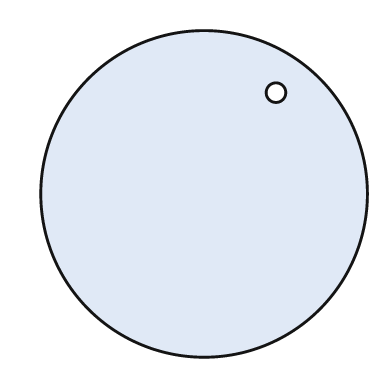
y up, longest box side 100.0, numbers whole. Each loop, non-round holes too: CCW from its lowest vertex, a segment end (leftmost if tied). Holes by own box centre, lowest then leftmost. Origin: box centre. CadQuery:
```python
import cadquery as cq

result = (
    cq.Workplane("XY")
    .moveTo(0.0, 0.0)
    .circle(50.0)
    .moveTo(22.0, 31.0)
    .circle(3.0)
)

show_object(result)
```